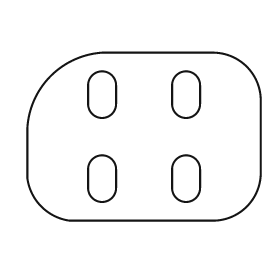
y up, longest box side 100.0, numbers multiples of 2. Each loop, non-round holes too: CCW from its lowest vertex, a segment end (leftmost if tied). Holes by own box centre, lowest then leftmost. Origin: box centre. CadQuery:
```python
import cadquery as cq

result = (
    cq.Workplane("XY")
    .moveTo(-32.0, -36.0)
    .lineTo(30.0, -36.0)
    .threePointArc((44.0, -30.0), (50.0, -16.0))
    .lineTo(50.0, 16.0)
    .threePointArc((44.0, 30.0), (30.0, 36.0))
    .lineTo(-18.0, 36.0)
    .threePointArc((-40.0, 26.0), (-50.0, 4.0))
    .lineTo(-50.0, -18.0)
    .threePointArc((-44.0, -30.0), (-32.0, -36.0))
    .close()
    .moveTo(-24.0, -22.0)
    .threePointArc((-18.0, -28.0), (-12.0, -22.0))
    .lineTo(-12.0, -14.0)
    .threePointArc((-18.0, -8.0), (-24.0, -14.0))
    .close()
    .moveTo(12.0, -22.0)
    .threePointArc((18.0, -28.0), (24.0, -22.0))
    .lineTo(24.0, -14.0)
    .threePointArc((18.0, -8.0), (12.0, -14.0))
    .close()
    .moveTo(-24.0, 14.0)
    .threePointArc((-18.0, 8.0), (-12.0, 14.0))
    .lineTo(-12.0, 22.0)
    .threePointArc((-18.0, 28.0), (-24.0, 22.0))
    .close()
    .moveTo(12.0, 14.0)
    .threePointArc((18.0, 8.0), (24.0, 14.0))
    .lineTo(24.0, 22.0)
    .threePointArc((18.0, 28.0), (12.0, 22.0))
    .close()
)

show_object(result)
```